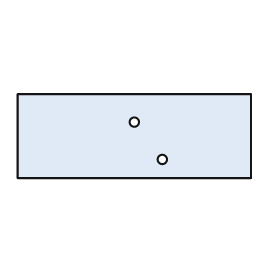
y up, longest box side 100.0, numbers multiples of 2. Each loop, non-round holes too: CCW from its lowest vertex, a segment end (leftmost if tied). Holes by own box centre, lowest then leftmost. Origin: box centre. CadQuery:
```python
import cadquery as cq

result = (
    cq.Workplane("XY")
    .moveTo(-50.0, -18.0)
    .lineTo(50.0, -18.0)
    .lineTo(50.0, 18.0)
    .lineTo(-50.0, 18.0)
    .close()
    .moveTo(12.0, -10.0)
    .circle(2.0)
    .moveTo(0.0, 6.0)
    .circle(2.0)
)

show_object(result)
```